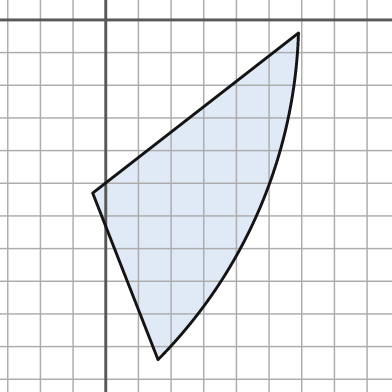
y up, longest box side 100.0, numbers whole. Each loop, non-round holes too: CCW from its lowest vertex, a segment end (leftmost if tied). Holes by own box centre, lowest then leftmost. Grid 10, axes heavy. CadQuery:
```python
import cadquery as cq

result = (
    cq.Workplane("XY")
    .moveTo(16.0, -104.0)
    .threePointArc((47.0, -58.0), (59.0, -4.0))
    .lineTo(-4.0, -53.0)
    .close()
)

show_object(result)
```